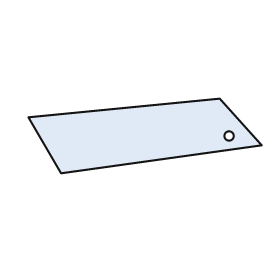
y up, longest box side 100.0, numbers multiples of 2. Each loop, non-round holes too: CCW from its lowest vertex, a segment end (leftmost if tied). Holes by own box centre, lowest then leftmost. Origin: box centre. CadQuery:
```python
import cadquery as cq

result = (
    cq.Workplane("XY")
    .moveTo(-36.0, -16.0)
    .lineTo(50.0, -4.0)
    .lineTo(32.0, 16.0)
    .lineTo(-50.0, 8.0)
    .close()
    .moveTo(36.0, 0.0)
    .circle(2.0)
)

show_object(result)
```